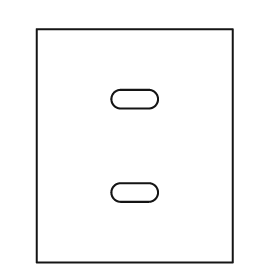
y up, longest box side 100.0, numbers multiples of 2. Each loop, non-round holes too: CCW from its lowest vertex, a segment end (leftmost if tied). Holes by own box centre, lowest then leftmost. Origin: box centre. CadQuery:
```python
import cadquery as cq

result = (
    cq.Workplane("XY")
    .moveTo(-42.0, -50.0)
    .lineTo(42.0, -50.0)
    .lineTo(42.0, 50.0)
    .lineTo(-42.0, 50.0)
    .close()
    .moveTo(-6.0, -24.0)
    .lineTo(6.0, -24.0)
    .threePointArc((10.0, -20.0), (6.0, -16.0))
    .lineTo(-6.0, -16.0)
    .threePointArc((-10.0, -20.0), (-6.0, -24.0))
    .close()
    .moveTo(-6.0, 16.0)
    .lineTo(6.0, 16.0)
    .threePointArc((10.0, 20.0), (6.0, 24.0))
    .lineTo(-6.0, 24.0)
    .threePointArc((-10.0, 20.0), (-6.0, 16.0))
    .close()
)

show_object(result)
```